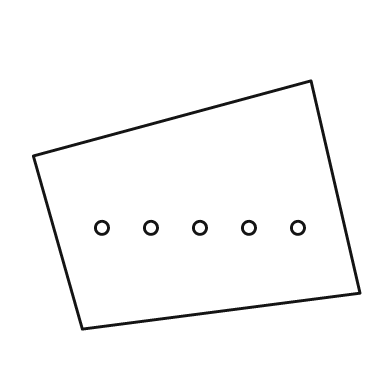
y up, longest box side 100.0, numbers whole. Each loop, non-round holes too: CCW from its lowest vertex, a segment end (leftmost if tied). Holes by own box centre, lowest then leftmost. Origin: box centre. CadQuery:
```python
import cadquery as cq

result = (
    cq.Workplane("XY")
    .moveTo(-35.0, -38.0)
    .lineTo(50.0, -27.0)
    .lineTo(35.0, 38.0)
    .lineTo(-50.0, 15.0)
    .close()
    .moveTo(-29.0, -7.0)
    .circle(2.0)
    .moveTo(-14.0, -7.0)
    .circle(2.0)
    .moveTo(1.0, -7.0)
    .circle(2.0)
    .moveTo(16.0, -7.0)
    .circle(2.0)
    .moveTo(31.0, -7.0)
    .circle(2.0)
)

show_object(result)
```